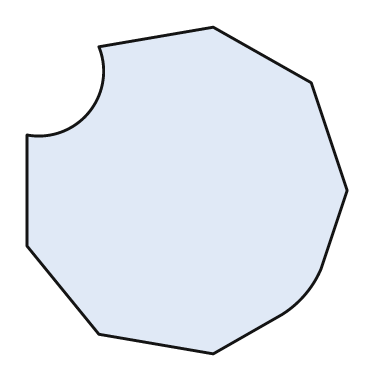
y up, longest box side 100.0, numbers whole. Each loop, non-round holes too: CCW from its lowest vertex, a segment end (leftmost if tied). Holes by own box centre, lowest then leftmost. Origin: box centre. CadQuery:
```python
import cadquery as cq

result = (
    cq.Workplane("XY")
    .moveTo(8.0, -50.0)
    .lineTo(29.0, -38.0)
    .threePointArc((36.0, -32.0), (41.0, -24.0))
    .lineTo(49.0, 0.0)
    .lineTo(38.0, 33.0)
    .lineTo(8.0, 50.0)
    .lineTo(-27.0, 44.0)
    .threePointArc((-30.0, 24.0), (-49.0, 17.0))
    .lineTo(-49.0, -17.0)
    .lineTo(-27.0, -44.0)
    .close()
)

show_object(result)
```